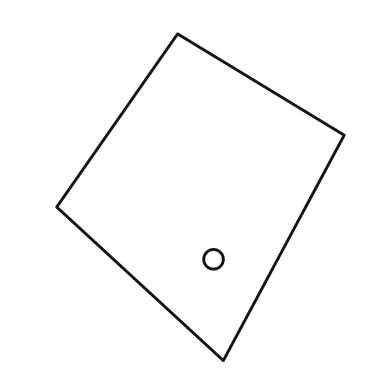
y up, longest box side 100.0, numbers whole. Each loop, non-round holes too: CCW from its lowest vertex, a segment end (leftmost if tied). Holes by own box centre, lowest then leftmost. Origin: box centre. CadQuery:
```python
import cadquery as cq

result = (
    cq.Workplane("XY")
    .moveTo(7.0, -50.0)
    .lineTo(44.0, 19.0)
    .lineTo(-7.0, 50.0)
    .lineTo(-44.0, -3.0)
    .close()
    .moveTo(4.0, -19.0)
    .circle(3.0)
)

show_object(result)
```